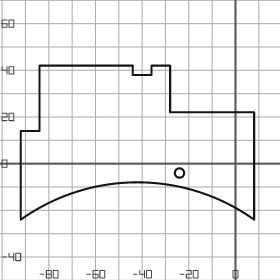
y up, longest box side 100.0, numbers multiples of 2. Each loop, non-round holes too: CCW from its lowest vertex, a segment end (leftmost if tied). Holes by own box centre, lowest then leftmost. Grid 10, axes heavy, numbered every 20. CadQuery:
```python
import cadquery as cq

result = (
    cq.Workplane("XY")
    .moveTo(-92.0, -24.0)
    .threePointArc((-42.0, -8.0), (8.0, -24.0))
    .lineTo(8.0, 22.0)
    .lineTo(-28.0, 22.0)
    .lineTo(-28.0, 42.0)
    .lineTo(-36.0, 42.0)
    .lineTo(-36.0, 38.0)
    .lineTo(-44.0, 38.0)
    .lineTo(-44.0, 42.0)
    .lineTo(-84.0, 42.0)
    .lineTo(-84.0, 14.0)
    .lineTo(-92.0, 14.0)
    .close()
    .moveTo(-24.0, -4.0)
    .circle(2.0)
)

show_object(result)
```